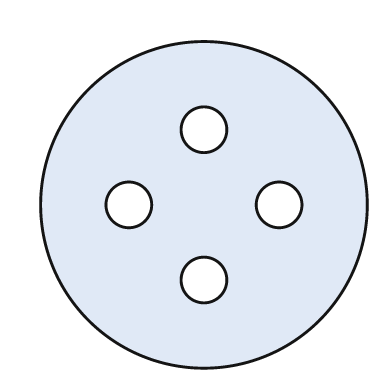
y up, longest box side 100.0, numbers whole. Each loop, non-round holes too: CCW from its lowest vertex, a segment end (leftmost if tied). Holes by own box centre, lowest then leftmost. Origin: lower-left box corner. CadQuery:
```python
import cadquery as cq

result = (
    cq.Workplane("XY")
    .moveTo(50.0, 50.0)
    .circle(50.0)
    .moveTo(50.0, 27.0)
    .circle(7.0)
    .moveTo(27.0, 50.0)
    .circle(7.0)
    .moveTo(73.0, 50.0)
    .circle(7.0)
    .moveTo(50.0, 73.0)
    .circle(7.0)
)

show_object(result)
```